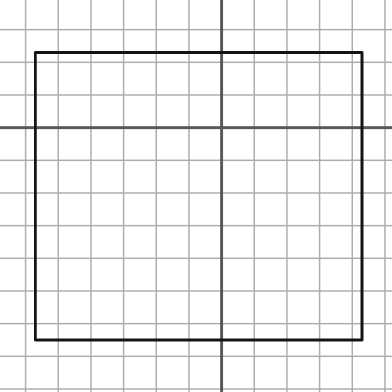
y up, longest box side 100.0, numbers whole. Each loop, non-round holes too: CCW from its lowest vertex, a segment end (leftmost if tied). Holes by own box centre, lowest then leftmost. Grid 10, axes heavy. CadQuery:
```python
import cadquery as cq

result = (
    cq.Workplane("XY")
    .moveTo(-57.0, -65.0)
    .lineTo(43.0, -65.0)
    .lineTo(43.0, 23.0)
    .lineTo(-57.0, 23.0)
    .close()
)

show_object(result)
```